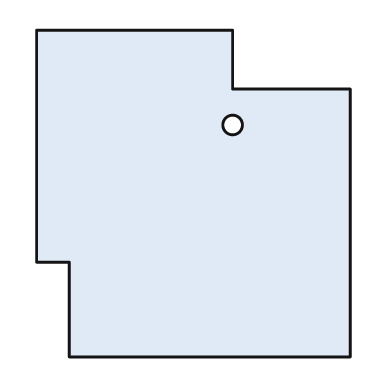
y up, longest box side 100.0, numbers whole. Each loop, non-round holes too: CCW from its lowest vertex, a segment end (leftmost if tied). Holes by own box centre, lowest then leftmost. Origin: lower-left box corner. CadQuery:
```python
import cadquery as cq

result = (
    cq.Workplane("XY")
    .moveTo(10.0, 0.0)
    .lineTo(96.0, 0.0)
    .lineTo(96.0, 82.0)
    .lineTo(60.0, 82.0)
    .lineTo(60.0, 100.0)
    .lineTo(0.0, 100.0)
    .lineTo(0.0, 29.0)
    .lineTo(10.0, 29.0)
    .close()
    .moveTo(60.0, 71.0)
    .circle(3.0)
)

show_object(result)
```